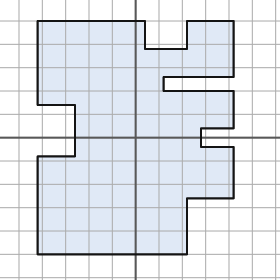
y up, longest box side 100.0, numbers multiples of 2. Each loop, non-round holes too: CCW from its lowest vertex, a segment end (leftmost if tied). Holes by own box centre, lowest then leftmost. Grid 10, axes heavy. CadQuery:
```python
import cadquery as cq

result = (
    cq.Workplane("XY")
    .moveTo(-42.0, -50.0)
    .lineTo(22.0, -50.0)
    .lineTo(22.0, -26.0)
    .lineTo(42.0, -26.0)
    .lineTo(42.0, -4.0)
    .lineTo(28.0, -4.0)
    .lineTo(28.0, 4.0)
    .lineTo(42.0, 4.0)
    .lineTo(42.0, 20.0)
    .lineTo(12.0, 20.0)
    .lineTo(12.0, 26.0)
    .lineTo(42.0, 26.0)
    .lineTo(42.0, 50.0)
    .lineTo(22.0, 50.0)
    .lineTo(22.0, 38.0)
    .lineTo(4.0, 38.0)
    .lineTo(4.0, 50.0)
    .lineTo(-42.0, 50.0)
    .lineTo(-42.0, 14.0)
    .lineTo(-26.0, 14.0)
    .lineTo(-26.0, -8.0)
    .lineTo(-42.0, -8.0)
    .close()
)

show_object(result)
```